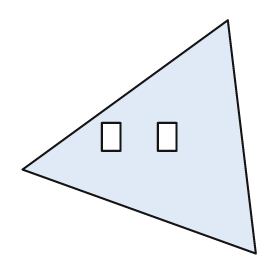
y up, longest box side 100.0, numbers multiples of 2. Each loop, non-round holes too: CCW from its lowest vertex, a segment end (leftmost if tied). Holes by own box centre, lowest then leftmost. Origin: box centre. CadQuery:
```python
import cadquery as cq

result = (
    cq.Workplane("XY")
    .moveTo(50.0, -50.0)
    .lineTo(38.0, 50.0)
    .lineTo(-50.0, -14.0)
    .close()
    .moveTo(-16.0, -6.0)
    .lineTo(-8.0, -6.0)
    .lineTo(-8.0, 6.0)
    .lineTo(-16.0, 6.0)
    .close()
    .moveTo(8.0, -6.0)
    .lineTo(16.0, -6.0)
    .lineTo(16.0, 6.0)
    .lineTo(8.0, 6.0)
    .close()
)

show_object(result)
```